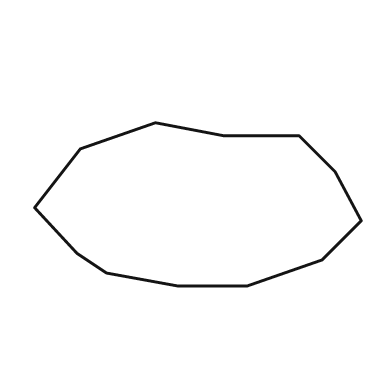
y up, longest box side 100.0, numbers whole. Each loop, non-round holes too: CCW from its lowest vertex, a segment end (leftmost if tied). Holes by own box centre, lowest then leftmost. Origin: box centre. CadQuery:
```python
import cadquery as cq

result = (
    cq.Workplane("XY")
    .moveTo(-6.0, -25.0)
    .lineTo(15.0, -25.0)
    .lineTo(38.0, -17.0)
    .lineTo(50.0, -5.0)
    .lineTo(42.0, 10.0)
    .lineTo(31.0, 21.0)
    .lineTo(8.0, 21.0)
    .lineTo(-13.0, 25.0)
    .lineTo(-36.0, 17.0)
    .lineTo(-50.0, -1.0)
    .lineTo(-37.0, -15.0)
    .lineTo(-28.0, -21.0)
    .close()
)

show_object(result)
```